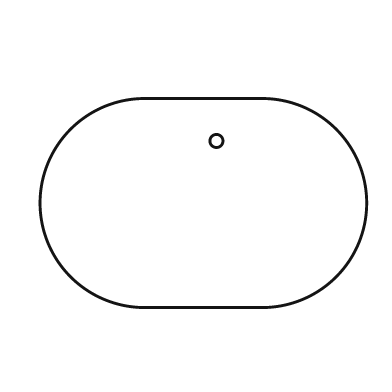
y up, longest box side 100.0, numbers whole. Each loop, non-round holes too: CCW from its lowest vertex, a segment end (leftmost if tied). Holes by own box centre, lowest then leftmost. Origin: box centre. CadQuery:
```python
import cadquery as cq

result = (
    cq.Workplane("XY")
    .moveTo(-18.0, -32.0)
    .lineTo(18.0, -32.0)
    .threePointArc((50.0, 0.0), (18.0, 32.0))
    .lineTo(-18.0, 32.0)
    .threePointArc((-50.0, 0.0), (-18.0, -32.0))
    .close()
    .moveTo(4.0, 19.0)
    .circle(2.0)
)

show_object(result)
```